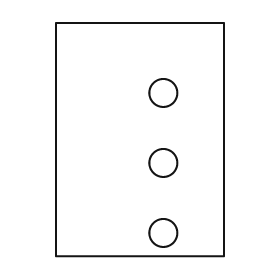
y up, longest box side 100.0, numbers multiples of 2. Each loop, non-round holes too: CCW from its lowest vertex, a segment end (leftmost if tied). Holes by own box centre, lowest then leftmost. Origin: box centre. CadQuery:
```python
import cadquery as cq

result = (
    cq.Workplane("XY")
    .moveTo(-36.0, -50.0)
    .lineTo(36.0, -50.0)
    .lineTo(36.0, 50.0)
    .lineTo(-36.0, 50.0)
    .close()
    .moveTo(10.0, -40.0)
    .circle(6.0)
    .moveTo(10.0, -10.0)
    .circle(6.0)
    .moveTo(10.0, 20.0)
    .circle(6.0)
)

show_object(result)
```